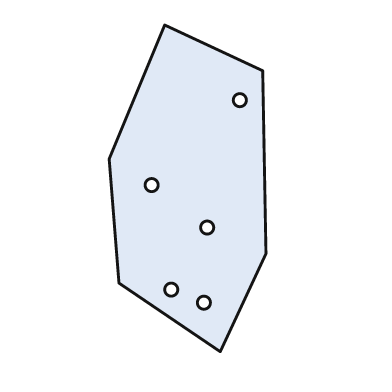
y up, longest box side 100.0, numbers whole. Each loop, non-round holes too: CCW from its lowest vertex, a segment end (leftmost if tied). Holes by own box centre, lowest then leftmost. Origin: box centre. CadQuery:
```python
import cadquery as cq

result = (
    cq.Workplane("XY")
    .moveTo(10.0, -50.0)
    .lineTo(24.0, -20.0)
    .lineTo(23.0, 36.0)
    .lineTo(-7.0, 50.0)
    .lineTo(-24.0, 9.0)
    .lineTo(-21.0, -29.0)
    .close()
    .moveTo(5.0, -35.0)
    .circle(2.0)
    .moveTo(-5.0, -31.0)
    .circle(2.0)
    .moveTo(6.0, -12.0)
    .circle(2.0)
    .moveTo(-11.0, 1.0)
    .circle(2.0)
    .moveTo(16.0, 27.0)
    .circle(2.0)
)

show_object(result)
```